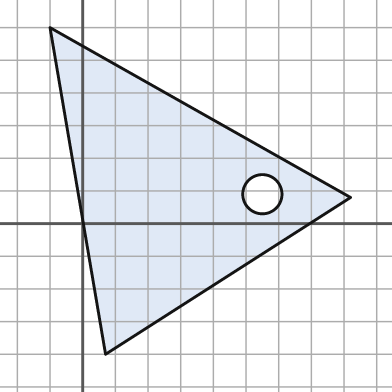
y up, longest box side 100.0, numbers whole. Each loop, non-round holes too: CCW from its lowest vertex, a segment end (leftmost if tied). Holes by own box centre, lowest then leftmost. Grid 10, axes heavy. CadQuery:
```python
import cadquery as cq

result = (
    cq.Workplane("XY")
    .moveTo(7.0, -40.0)
    .lineTo(82.0, 8.0)
    .lineTo(-10.0, 60.0)
    .close()
    .moveTo(55.0, 9.0)
    .circle(6.0)
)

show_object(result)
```